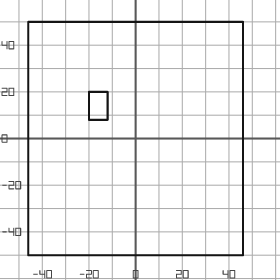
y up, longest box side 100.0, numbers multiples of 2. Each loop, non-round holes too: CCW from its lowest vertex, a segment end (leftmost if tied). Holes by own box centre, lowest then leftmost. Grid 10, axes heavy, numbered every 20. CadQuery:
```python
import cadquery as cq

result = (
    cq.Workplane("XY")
    .moveTo(-46.0, -50.0)
    .lineTo(46.0, -50.0)
    .lineTo(46.0, 50.0)
    .lineTo(-46.0, 50.0)
    .close()
    .moveTo(-20.0, 8.0)
    .lineTo(-12.0, 8.0)
    .lineTo(-12.0, 20.0)
    .lineTo(-20.0, 20.0)
    .close()
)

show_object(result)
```